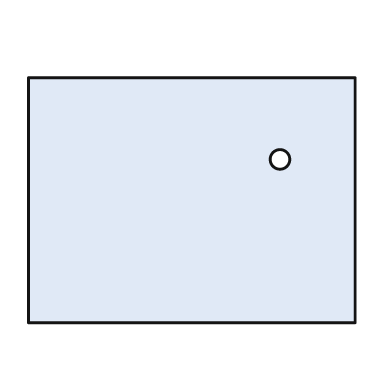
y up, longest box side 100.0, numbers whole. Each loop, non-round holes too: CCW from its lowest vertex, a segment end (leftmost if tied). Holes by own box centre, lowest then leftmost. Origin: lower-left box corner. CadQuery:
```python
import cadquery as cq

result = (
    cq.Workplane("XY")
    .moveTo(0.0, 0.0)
    .lineTo(100.0, 0.0)
    .lineTo(100.0, 75.0)
    .lineTo(0.0, 75.0)
    .close()
    .moveTo(77.0, 50.0)
    .circle(3.0)
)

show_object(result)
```